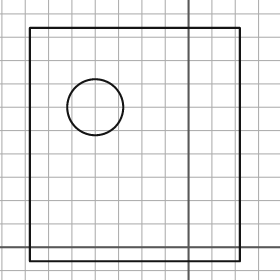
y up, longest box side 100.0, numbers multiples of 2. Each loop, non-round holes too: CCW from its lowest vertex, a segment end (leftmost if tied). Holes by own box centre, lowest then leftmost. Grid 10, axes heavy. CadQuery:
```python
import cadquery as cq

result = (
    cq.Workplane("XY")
    .moveTo(-68.0, -6.0)
    .lineTo(22.0, -6.0)
    .lineTo(22.0, 94.0)
    .lineTo(-68.0, 94.0)
    .close()
    .moveTo(-40.0, 60.0)
    .circle(12.0)
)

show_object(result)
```